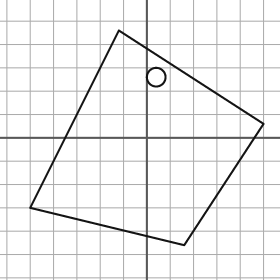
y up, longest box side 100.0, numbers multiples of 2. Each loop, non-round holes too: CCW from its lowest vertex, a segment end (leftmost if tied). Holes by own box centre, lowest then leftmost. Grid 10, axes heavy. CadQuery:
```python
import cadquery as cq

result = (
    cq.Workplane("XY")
    .moveTo(16.0, -46.0)
    .lineTo(50.0, 6.0)
    .lineTo(-12.0, 46.0)
    .lineTo(-50.0, -30.0)
    .close()
    .moveTo(4.0, 26.0)
    .circle(4.0)
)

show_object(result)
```